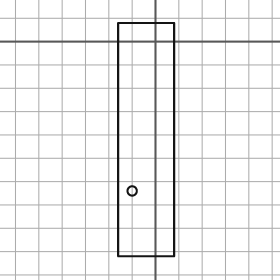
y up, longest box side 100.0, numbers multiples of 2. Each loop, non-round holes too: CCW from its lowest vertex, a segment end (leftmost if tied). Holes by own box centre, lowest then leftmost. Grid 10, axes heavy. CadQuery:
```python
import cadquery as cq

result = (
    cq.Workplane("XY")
    .moveTo(-16.0, -92.0)
    .lineTo(8.0, -92.0)
    .lineTo(8.0, 8.0)
    .lineTo(-16.0, 8.0)
    .close()
    .moveTo(-10.0, -64.0)
    .circle(2.0)
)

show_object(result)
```